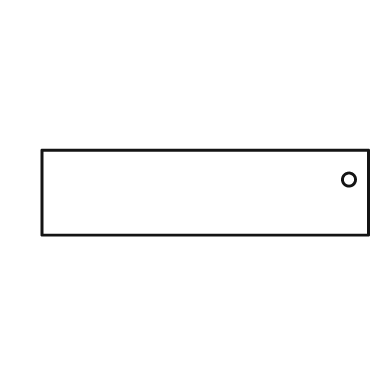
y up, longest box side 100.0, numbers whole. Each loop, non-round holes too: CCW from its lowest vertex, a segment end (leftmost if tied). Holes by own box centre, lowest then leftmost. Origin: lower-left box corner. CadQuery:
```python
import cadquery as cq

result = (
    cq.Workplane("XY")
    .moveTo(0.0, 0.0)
    .lineTo(100.0, 0.0)
    .lineTo(100.0, 26.0)
    .lineTo(0.0, 26.0)
    .close()
    .moveTo(94.0, 17.0)
    .circle(2.0)
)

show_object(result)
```